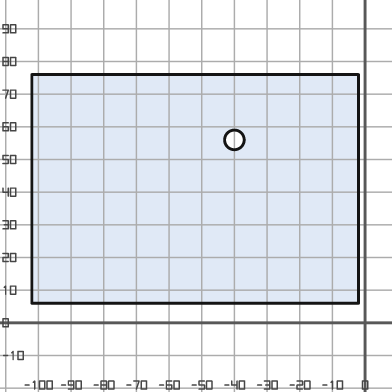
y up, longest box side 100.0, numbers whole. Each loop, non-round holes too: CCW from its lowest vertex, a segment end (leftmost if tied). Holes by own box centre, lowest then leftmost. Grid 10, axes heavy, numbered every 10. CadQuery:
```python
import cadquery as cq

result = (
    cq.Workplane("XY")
    .moveTo(-102.0, 6.0)
    .lineTo(-2.0, 6.0)
    .lineTo(-2.0, 76.0)
    .lineTo(-102.0, 76.0)
    .close()
    .moveTo(-40.0, 56.0)
    .circle(3.0)
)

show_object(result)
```